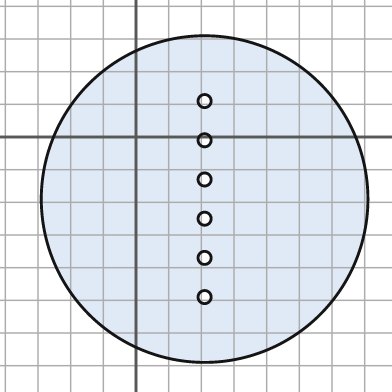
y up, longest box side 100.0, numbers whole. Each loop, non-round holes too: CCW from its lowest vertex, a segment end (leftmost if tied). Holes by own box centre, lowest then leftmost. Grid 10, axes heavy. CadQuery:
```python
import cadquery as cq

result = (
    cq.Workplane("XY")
    .moveTo(21.0, -19.0)
    .circle(50.0)
    .moveTo(21.0, -49.0)
    .circle(2.0)
    .moveTo(21.0, -37.0)
    .circle(2.0)
    .moveTo(21.0, -25.0)
    .circle(2.0)
    .moveTo(21.0, -13.0)
    .circle(2.0)
    .moveTo(21.0, -1.0)
    .circle(2.0)
    .moveTo(21.0, 11.0)
    .circle(2.0)
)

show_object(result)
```